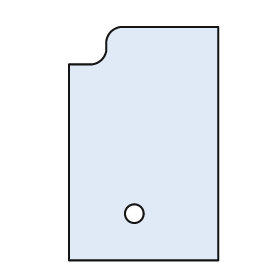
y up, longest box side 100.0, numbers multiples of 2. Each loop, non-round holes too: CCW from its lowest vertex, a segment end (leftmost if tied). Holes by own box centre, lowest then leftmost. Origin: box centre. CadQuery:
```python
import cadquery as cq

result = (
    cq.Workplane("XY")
    .moveTo(-32.0, -50.0)
    .lineTo(32.0, -50.0)
    .lineTo(32.0, 50.0)
    .lineTo(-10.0, 50.0)
    .threePointArc((-14.0, 48.0), (-16.0, 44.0))
    .lineTo(-16.0, 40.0)
    .threePointArc((-18.0, 36.0), (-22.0, 34.0))
    .lineTo(-32.0, 34.0)
    .close()
    .moveTo(-4.0, -30.0)
    .circle(4.0)
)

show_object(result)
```